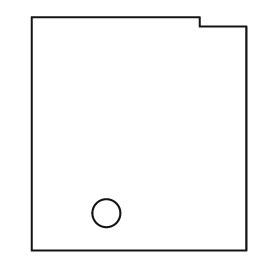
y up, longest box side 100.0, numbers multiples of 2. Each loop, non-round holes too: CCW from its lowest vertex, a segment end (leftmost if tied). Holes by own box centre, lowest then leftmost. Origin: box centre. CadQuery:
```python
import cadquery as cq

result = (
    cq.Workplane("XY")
    .moveTo(-46.0, -50.0)
    .lineTo(46.0, -50.0)
    .lineTo(46.0, 46.0)
    .lineTo(26.0, 46.0)
    .lineTo(26.0, 50.0)
    .lineTo(-46.0, 50.0)
    .close()
    .moveTo(-14.0, -34.0)
    .circle(6.0)
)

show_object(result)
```